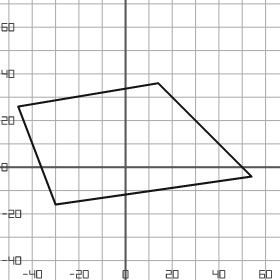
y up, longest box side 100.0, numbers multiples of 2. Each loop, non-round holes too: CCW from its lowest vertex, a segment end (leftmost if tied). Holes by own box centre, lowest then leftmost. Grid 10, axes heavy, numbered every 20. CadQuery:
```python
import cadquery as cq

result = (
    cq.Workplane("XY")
    .moveTo(-30.0, -16.0)
    .lineTo(54.0, -4.0)
    .lineTo(14.0, 36.0)
    .lineTo(-46.0, 26.0)
    .close()
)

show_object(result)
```